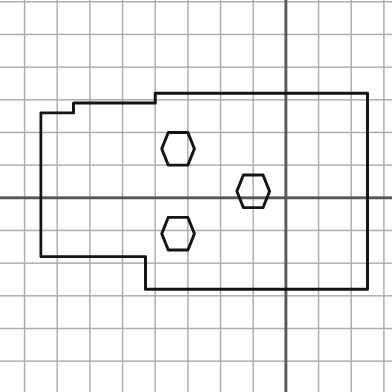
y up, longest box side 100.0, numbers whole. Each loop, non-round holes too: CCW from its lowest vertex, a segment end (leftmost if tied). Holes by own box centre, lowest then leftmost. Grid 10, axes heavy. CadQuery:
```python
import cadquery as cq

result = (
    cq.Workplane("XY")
    .moveTo(-43.0, -28.0)
    .lineTo(25.0, -28.0)
    .lineTo(25.0, 32.0)
    .lineTo(-40.0, 32.0)
    .lineTo(-40.0, 29.0)
    .lineTo(-65.0, 29.0)
    .lineTo(-65.0, 26.0)
    .lineTo(-75.0, 26.0)
    .lineTo(-75.0, -18.0)
    .lineTo(-43.0, -18.0)
    .close()
    .moveTo(-36.0, -16.0)
    .lineTo(-30.0, -16.0)
    .lineTo(-28.0, -11.0)
    .lineTo(-30.0, -6.0)
    .lineTo(-36.0, -6.0)
    .lineTo(-38.0, -11.0)
    .close()
    .moveTo(-13.0, -3.0)
    .lineTo(-7.0, -3.0)
    .lineTo(-5.0, 2.0)
    .lineTo(-7.0, 7.0)
    .lineTo(-13.0, 7.0)
    .lineTo(-15.0, 2.0)
    .close()
    .moveTo(-36.0, 10.0)
    .lineTo(-30.0, 10.0)
    .lineTo(-28.0, 15.0)
    .lineTo(-30.0, 20.0)
    .lineTo(-36.0, 20.0)
    .lineTo(-38.0, 15.0)
    .close()
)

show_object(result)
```